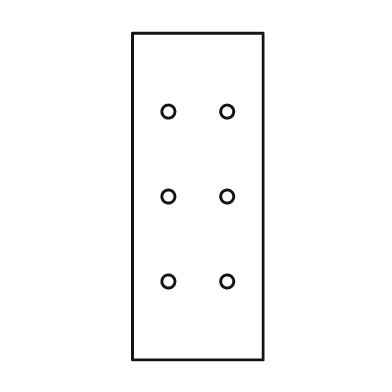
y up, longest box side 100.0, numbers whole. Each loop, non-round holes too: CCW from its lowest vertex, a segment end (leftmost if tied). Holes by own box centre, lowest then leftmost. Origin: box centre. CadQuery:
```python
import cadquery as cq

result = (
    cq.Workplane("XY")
    .moveTo(-20.0, -50.0)
    .lineTo(20.0, -50.0)
    .lineTo(20.0, 50.0)
    .lineTo(-20.0, 50.0)
    .close()
    .moveTo(-9.0, -26.0)
    .circle(2.0)
    .moveTo(9.0, -26.0)
    .circle(2.0)
    .moveTo(-9.0, 0.0)
    .circle(2.0)
    .moveTo(9.0, 0.0)
    .circle(2.0)
    .moveTo(-9.0, 26.0)
    .circle(2.0)
    .moveTo(9.0, 26.0)
    .circle(2.0)
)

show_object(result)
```